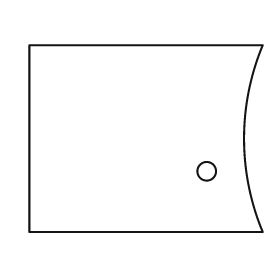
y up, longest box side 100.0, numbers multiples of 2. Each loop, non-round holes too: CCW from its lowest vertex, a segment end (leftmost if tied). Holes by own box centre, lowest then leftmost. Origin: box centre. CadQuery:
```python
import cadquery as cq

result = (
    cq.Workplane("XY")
    .moveTo(-50.0, -40.0)
    .lineTo(50.0, -40.0)
    .threePointArc((42.0, 0.0), (50.0, 40.0))
    .lineTo(-50.0, 40.0)
    .close()
    .moveTo(26.0, -14.0)
    .circle(4.0)
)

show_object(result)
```